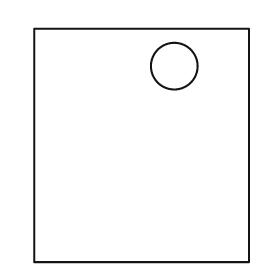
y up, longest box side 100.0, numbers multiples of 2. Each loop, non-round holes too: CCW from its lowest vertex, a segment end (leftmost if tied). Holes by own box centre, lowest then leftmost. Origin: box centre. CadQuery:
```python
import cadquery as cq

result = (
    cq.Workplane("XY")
    .moveTo(-46.0, -50.0)
    .lineTo(46.0, -50.0)
    .lineTo(46.0, 50.0)
    .lineTo(-46.0, 50.0)
    .close()
    .moveTo(14.0, 34.0)
    .circle(10.0)
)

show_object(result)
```